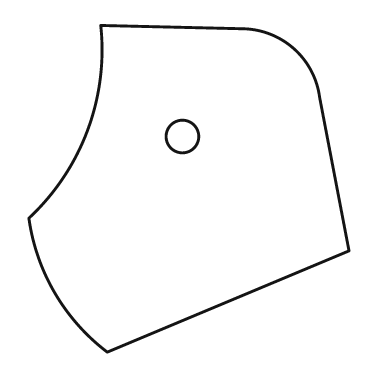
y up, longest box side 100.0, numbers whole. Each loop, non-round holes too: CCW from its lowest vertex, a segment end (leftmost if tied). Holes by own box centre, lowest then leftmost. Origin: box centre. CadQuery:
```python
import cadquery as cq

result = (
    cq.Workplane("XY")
    .moveTo(-25.0, -50.0)
    .lineTo(49.0, -19.0)
    .lineTo(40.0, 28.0)
    .threePointArc((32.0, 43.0), (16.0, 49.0))
    .lineTo(-27.0, 50.0)
    .threePointArc((-31.0, 18.0), (-49.0, -9.0))
    .threePointArc((-41.0, -32.0), (-25.0, -50.0))
    .close()
    .moveTo(-2.0, 16.0)
    .circle(5.0)
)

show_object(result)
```